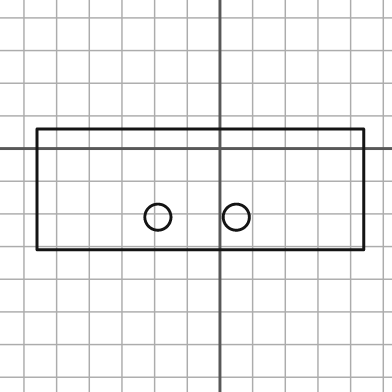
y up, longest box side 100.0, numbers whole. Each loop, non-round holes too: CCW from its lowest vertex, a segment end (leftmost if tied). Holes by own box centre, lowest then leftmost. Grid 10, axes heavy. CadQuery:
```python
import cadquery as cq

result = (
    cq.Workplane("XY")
    .moveTo(-56.0, -31.0)
    .lineTo(44.0, -31.0)
    .lineTo(44.0, 6.0)
    .lineTo(-56.0, 6.0)
    .close()
    .moveTo(-19.0, -21.0)
    .circle(4.0)
    .moveTo(5.0, -21.0)
    .circle(4.0)
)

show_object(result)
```